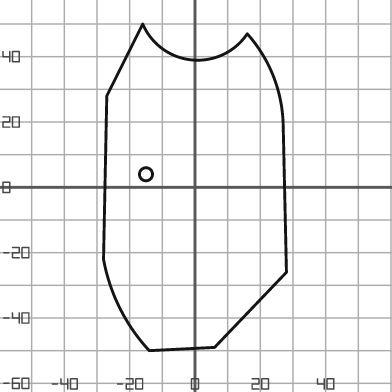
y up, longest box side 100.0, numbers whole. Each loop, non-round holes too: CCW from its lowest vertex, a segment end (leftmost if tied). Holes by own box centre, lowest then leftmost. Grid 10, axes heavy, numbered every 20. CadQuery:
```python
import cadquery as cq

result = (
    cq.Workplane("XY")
    .moveTo(-14.0, -50.0)
    .lineTo(6.0, -49.0)
    .lineTo(28.0, -26.0)
    .lineTo(27.0, 19.0)
    .threePointArc((24.0, 34.0), (16.0, 47.0))
    .threePointArc((-1.0, 39.0), (-16.0, 50.0))
    .lineTo(-27.0, 28.0)
    .lineTo(-28.0, -22.0)
    .threePointArc((-23.0, -37.0), (-14.0, -50.0))
    .close()
    .moveTo(-15.0, 4.0)
    .circle(2.0)
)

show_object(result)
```